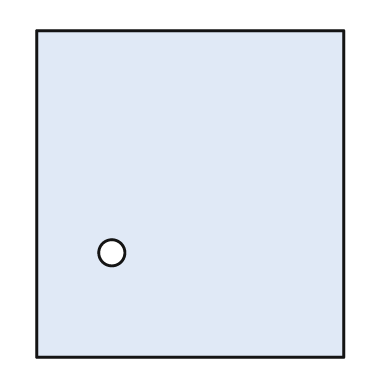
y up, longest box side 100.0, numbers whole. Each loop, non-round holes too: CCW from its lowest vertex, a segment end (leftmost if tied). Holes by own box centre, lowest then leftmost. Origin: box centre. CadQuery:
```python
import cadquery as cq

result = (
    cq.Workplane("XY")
    .moveTo(-47.0, -50.0)
    .lineTo(47.0, -50.0)
    .lineTo(47.0, 50.0)
    .lineTo(-47.0, 50.0)
    .close()
    .moveTo(-24.0, -18.0)
    .circle(4.0)
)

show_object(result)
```